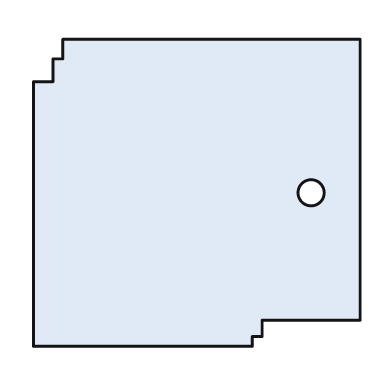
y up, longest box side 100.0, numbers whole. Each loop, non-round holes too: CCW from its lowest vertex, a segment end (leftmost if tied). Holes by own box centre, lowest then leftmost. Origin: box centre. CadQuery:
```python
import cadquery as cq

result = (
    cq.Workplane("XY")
    .moveTo(-50.0, -47.0)
    .lineTo(17.0, -47.0)
    .lineTo(17.0, -44.0)
    .lineTo(20.0, -44.0)
    .lineTo(20.0, -39.0)
    .lineTo(50.0, -39.0)
    .lineTo(50.0, 47.0)
    .lineTo(-41.0, 47.0)
    .lineTo(-41.0, 41.0)
    .lineTo(-44.0, 41.0)
    .lineTo(-44.0, 34.0)
    .lineTo(-50.0, 34.0)
    .close()
    .moveTo(35.0, 0.0)
    .circle(4.0)
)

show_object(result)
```